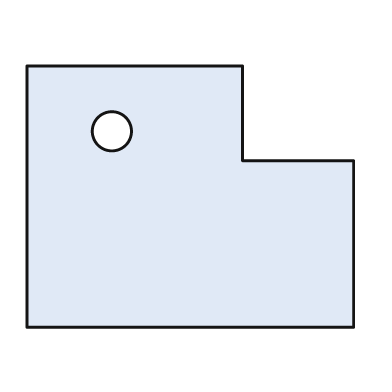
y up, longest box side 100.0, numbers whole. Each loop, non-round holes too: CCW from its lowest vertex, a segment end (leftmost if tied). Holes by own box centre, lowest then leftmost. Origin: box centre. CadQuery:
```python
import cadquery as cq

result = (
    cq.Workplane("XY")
    .moveTo(-50.0, -40.0)
    .lineTo(50.0, -40.0)
    .lineTo(50.0, 11.0)
    .lineTo(16.0, 11.0)
    .lineTo(16.0, 40.0)
    .lineTo(-50.0, 40.0)
    .close()
    .moveTo(-24.0, 20.0)
    .circle(6.0)
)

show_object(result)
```